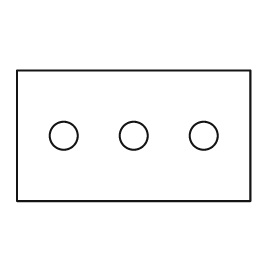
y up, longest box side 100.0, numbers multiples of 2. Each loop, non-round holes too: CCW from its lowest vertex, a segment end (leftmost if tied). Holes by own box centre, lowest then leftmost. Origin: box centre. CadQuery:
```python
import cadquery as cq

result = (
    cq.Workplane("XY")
    .moveTo(-50.0, -28.0)
    .lineTo(50.0, -28.0)
    .lineTo(50.0, 28.0)
    .lineTo(-50.0, 28.0)
    .close()
    .moveTo(-30.0, 0.0)
    .circle(6.0)
    .moveTo(0.0, 0.0)
    .circle(6.0)
    .moveTo(30.0, 0.0)
    .circle(6.0)
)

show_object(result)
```